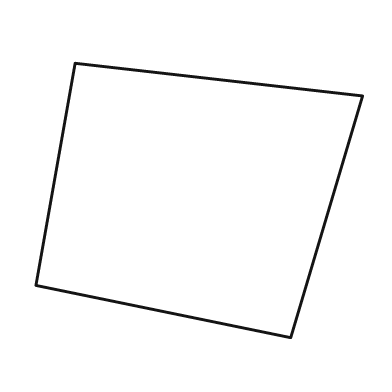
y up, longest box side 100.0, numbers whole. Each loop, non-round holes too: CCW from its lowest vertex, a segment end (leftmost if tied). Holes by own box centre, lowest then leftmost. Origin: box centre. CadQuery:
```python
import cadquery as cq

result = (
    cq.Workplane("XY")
    .moveTo(28.0, -42.0)
    .lineTo(50.0, 32.0)
    .lineTo(-38.0, 42.0)
    .lineTo(-50.0, -26.0)
    .close()
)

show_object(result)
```